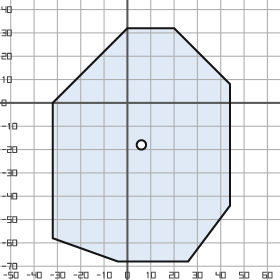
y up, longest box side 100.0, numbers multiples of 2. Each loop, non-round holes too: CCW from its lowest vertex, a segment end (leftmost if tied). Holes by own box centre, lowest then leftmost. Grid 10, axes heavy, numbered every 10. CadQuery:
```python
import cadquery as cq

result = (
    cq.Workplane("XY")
    .moveTo(-4.0, -68.0)
    .lineTo(26.0, -68.0)
    .lineTo(44.0, -44.0)
    .lineTo(44.0, 8.0)
    .lineTo(20.0, 32.0)
    .lineTo(0.0, 32.0)
    .lineTo(-32.0, 0.0)
    .lineTo(-32.0, -58.0)
    .close()
    .moveTo(6.0, -18.0)
    .circle(2.0)
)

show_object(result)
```